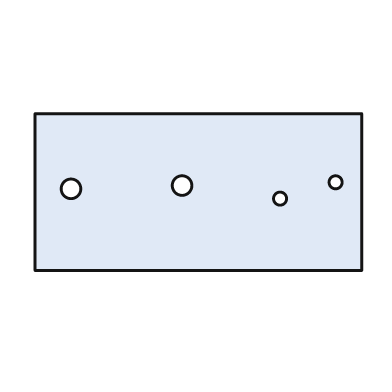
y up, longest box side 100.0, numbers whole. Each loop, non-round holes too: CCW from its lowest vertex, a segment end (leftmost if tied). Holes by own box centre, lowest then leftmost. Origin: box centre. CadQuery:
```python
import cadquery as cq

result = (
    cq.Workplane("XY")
    .moveTo(-50.0, -24.0)
    .lineTo(50.0, -24.0)
    .lineTo(50.0, 24.0)
    .lineTo(-50.0, 24.0)
    .close()
    .moveTo(25.0, -2.0)
    .circle(2.0)
    .moveTo(-39.0, 1.0)
    .circle(3.0)
    .moveTo(-5.0, 2.0)
    .circle(3.0)
    .moveTo(42.0, 3.0)
    .circle(2.0)
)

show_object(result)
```